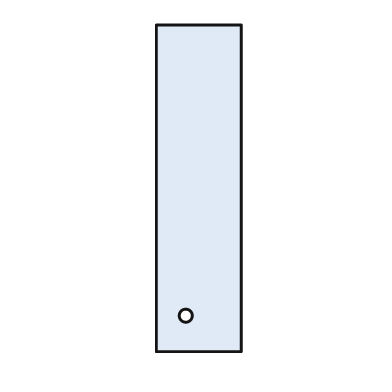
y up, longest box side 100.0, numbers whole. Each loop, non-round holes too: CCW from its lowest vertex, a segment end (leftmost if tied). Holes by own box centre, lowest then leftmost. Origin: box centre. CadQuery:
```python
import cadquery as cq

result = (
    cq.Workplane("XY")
    .moveTo(-13.0, -50.0)
    .lineTo(13.0, -50.0)
    .lineTo(13.0, 50.0)
    .lineTo(-13.0, 50.0)
    .close()
    .moveTo(-4.0, -39.0)
    .circle(2.0)
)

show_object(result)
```